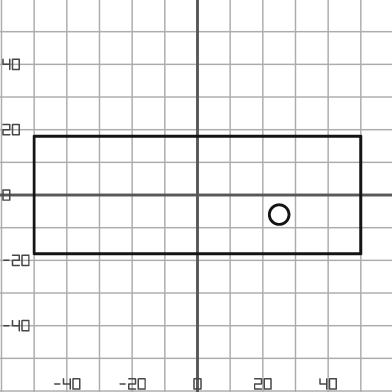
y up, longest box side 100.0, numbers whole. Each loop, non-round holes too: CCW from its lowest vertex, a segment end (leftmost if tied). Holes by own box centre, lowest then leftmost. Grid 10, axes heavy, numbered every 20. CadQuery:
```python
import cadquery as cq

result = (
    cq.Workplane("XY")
    .moveTo(-50.0, -18.0)
    .lineTo(50.0, -18.0)
    .lineTo(50.0, 18.0)
    .lineTo(-50.0, 18.0)
    .close()
    .moveTo(25.0, -6.0)
    .circle(3.0)
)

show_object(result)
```